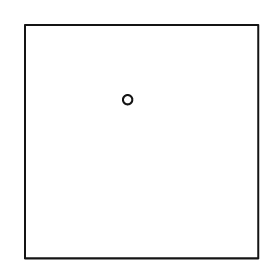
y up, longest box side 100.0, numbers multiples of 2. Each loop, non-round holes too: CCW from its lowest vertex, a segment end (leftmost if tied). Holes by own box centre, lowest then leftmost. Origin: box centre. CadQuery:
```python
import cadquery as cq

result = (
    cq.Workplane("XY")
    .moveTo(-50.0, -50.0)
    .lineTo(50.0, -50.0)
    .lineTo(50.0, 50.0)
    .lineTo(-50.0, 50.0)
    .close()
    .moveTo(-6.0, 18.0)
    .circle(2.0)
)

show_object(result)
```